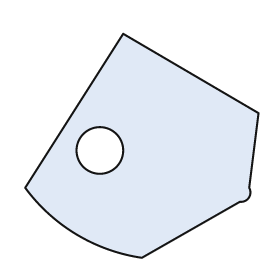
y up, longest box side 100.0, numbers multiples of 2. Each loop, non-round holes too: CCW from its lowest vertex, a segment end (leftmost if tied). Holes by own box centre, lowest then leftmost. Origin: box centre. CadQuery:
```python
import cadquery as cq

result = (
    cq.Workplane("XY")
    .moveTo(0.0, -48.0)
    .lineTo(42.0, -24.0)
    .threePointArc((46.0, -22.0), (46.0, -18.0))
    .lineTo(50.0, 14.0)
    .lineTo(-8.0, 48.0)
    .lineTo(-50.0, -18.0)
    .threePointArc((-28.0, -38.0), (0.0, -48.0))
    .close()
    .moveTo(-18.0, -2.0)
    .circle(10.0)
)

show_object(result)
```